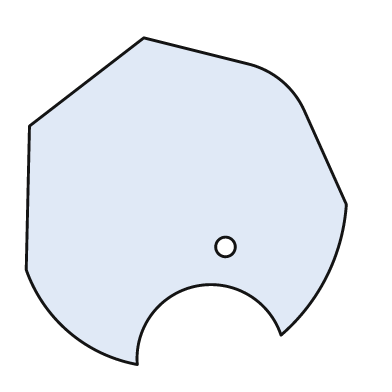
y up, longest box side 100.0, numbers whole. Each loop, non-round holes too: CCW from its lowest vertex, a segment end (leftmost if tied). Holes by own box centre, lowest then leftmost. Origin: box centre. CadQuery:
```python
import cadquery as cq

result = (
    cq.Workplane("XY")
    .moveTo(-15.0, -50.0)
    .threePointArc((3.0, -26.0), (29.0, -41.0))
    .threePointArc((43.0, -23.0), (49.0, -1.0))
    .lineTo(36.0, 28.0)
    .threePointArc((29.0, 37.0), (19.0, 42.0))
    .lineTo(-13.0, 50.0)
    .lineTo(-48.0, 23.0)
    .lineTo(-49.0, -21.0)
    .threePointArc((-36.0, -40.0), (-15.0, -50.0))
    .close()
    .moveTo(12.0, -14.0)
    .circle(3.0)
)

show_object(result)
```